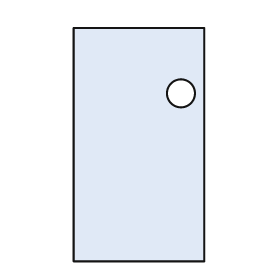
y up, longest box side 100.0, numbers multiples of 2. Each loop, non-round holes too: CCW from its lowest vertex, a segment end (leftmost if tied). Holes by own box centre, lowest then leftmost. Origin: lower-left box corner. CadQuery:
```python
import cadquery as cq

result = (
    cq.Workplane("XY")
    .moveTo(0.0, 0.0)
    .lineTo(56.0, 0.0)
    .lineTo(56.0, 100.0)
    .lineTo(0.0, 100.0)
    .close()
    .moveTo(46.0, 72.0)
    .circle(6.0)
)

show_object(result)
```